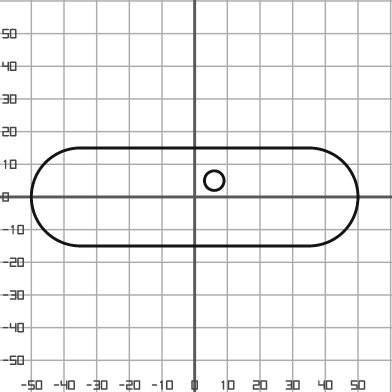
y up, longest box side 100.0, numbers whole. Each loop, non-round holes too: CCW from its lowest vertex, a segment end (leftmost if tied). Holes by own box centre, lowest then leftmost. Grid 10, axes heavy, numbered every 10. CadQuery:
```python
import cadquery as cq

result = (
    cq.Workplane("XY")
    .moveTo(-35.0, -15.0)
    .lineTo(35.0, -15.0)
    .threePointArc((50.0, 0.0), (35.0, 15.0))
    .lineTo(-35.0, 15.0)
    .threePointArc((-50.0, 0.0), (-35.0, -15.0))
    .close()
    .moveTo(6.0, 5.0)
    .circle(3.0)
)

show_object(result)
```